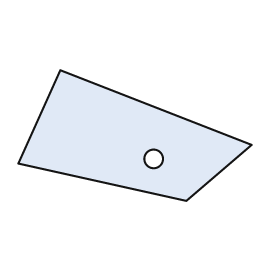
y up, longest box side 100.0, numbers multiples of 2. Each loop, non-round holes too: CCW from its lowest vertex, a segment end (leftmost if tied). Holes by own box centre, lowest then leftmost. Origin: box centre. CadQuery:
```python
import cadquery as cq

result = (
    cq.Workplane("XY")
    .moveTo(22.0, -28.0)
    .lineTo(50.0, -4.0)
    .lineTo(-32.0, 28.0)
    .lineTo(-50.0, -12.0)
    .close()
    .moveTo(8.0, -10.0)
    .circle(4.0)
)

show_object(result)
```